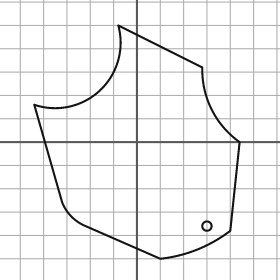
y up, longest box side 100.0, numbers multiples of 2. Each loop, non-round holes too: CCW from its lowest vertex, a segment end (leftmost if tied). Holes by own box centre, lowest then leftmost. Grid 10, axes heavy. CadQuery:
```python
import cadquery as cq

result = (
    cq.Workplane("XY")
    .moveTo(10.0, -50.0)
    .threePointArc((26.0, -46.0), (40.0, -38.0))
    .lineTo(44.0, 0.0)
    .threePointArc((32.0, 14.0), (28.0, 32.0))
    .lineTo(-8.0, 50.0)
    .threePointArc((-16.0, 22.0), (-44.0, 16.0))
    .lineTo(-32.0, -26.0)
    .threePointArc((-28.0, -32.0), (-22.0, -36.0))
    .close()
    .moveTo(30.0, -36.0)
    .circle(2.0)
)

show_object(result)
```